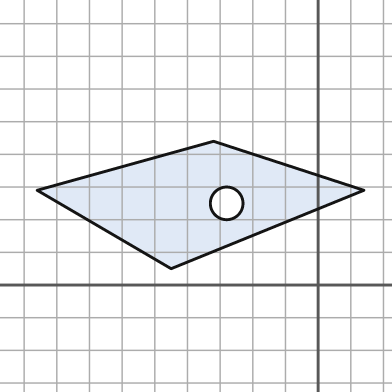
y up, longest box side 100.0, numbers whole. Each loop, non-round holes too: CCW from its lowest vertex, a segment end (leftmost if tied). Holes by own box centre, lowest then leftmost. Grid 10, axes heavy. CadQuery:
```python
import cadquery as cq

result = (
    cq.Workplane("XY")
    .moveTo(-45.0, 5.0)
    .lineTo(14.0, 29.0)
    .lineTo(-32.0, 44.0)
    .lineTo(-86.0, 29.0)
    .close()
    .moveTo(-28.0, 25.0)
    .circle(5.0)
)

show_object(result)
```